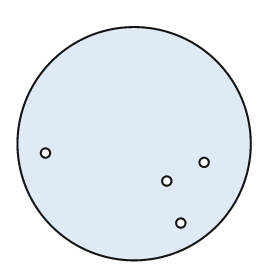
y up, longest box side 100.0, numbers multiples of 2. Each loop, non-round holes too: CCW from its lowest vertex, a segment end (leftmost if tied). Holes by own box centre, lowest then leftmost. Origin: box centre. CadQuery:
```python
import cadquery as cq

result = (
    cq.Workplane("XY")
    .moveTo(0.0, 0.0)
    .circle(50.0)
    .moveTo(20.0, -34.0)
    .circle(2.0)
    .moveTo(14.0, -16.0)
    .circle(2.0)
    .moveTo(30.0, -8.0)
    .circle(2.0)
    .moveTo(-38.0, -4.0)
    .circle(2.0)
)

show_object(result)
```